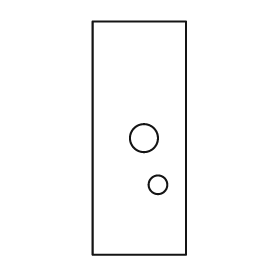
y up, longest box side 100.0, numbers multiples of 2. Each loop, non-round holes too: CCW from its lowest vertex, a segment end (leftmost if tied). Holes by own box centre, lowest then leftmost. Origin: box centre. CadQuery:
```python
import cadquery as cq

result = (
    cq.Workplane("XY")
    .moveTo(-20.0, -50.0)
    .lineTo(20.0, -50.0)
    .lineTo(20.0, 50.0)
    .lineTo(-20.0, 50.0)
    .close()
    .moveTo(8.0, -20.0)
    .circle(4.0)
    .moveTo(2.0, 0.0)
    .circle(6.0)
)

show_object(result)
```